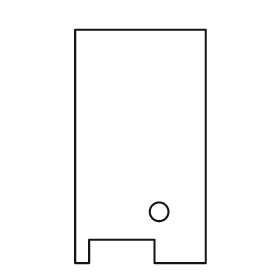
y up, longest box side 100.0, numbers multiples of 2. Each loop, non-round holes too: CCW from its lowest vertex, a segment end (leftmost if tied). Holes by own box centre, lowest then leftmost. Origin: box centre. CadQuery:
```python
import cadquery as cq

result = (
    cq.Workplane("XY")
    .moveTo(-28.0, -50.0)
    .lineTo(-22.0, -50.0)
    .lineTo(-22.0, -40.0)
    .lineTo(6.0, -40.0)
    .lineTo(6.0, -50.0)
    .lineTo(28.0, -50.0)
    .lineTo(28.0, 50.0)
    .lineTo(-28.0, 50.0)
    .close()
    .moveTo(8.0, -28.0)
    .circle(4.0)
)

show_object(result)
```